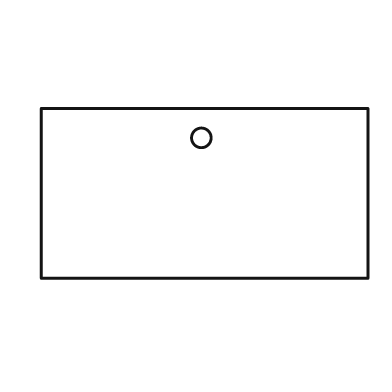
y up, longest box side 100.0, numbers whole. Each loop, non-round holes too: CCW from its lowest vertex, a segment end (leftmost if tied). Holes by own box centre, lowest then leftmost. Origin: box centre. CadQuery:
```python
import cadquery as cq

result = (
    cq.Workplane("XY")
    .moveTo(-50.0, -26.0)
    .lineTo(50.0, -26.0)
    .lineTo(50.0, 26.0)
    .lineTo(-50.0, 26.0)
    .close()
    .moveTo(-1.0, 17.0)
    .circle(3.0)
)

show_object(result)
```